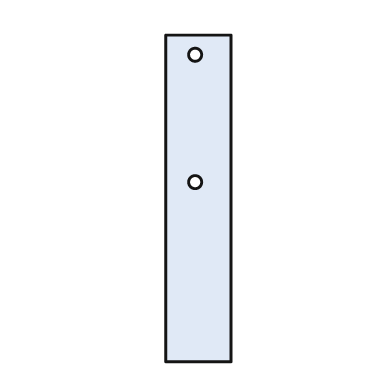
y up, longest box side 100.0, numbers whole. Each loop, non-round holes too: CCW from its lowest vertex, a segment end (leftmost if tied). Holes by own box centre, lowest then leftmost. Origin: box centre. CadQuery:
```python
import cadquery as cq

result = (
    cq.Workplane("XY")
    .moveTo(-10.0, -50.0)
    .lineTo(10.0, -50.0)
    .lineTo(10.0, 50.0)
    .lineTo(-10.0, 50.0)
    .close()
    .moveTo(-1.0, 5.0)
    .circle(2.0)
    .moveTo(-1.0, 44.0)
    .circle(2.0)
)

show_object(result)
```